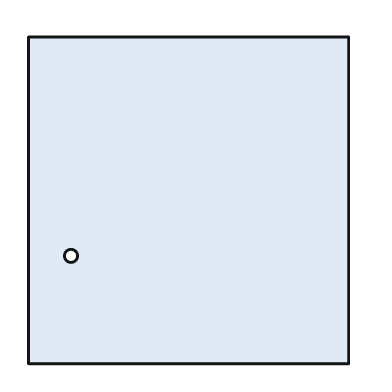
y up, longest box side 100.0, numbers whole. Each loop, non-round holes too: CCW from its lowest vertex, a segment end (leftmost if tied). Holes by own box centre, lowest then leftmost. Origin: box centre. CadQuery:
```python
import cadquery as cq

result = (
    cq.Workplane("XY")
    .moveTo(-49.0, -50.0)
    .lineTo(49.0, -50.0)
    .lineTo(49.0, 50.0)
    .lineTo(-49.0, 50.0)
    .close()
    .moveTo(-36.0, -17.0)
    .circle(2.0)
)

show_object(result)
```